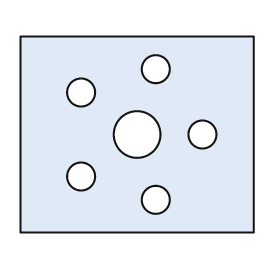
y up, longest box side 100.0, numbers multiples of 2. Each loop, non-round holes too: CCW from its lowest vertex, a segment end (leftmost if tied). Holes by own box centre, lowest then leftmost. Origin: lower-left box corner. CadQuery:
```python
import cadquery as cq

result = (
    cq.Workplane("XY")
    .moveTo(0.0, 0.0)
    .lineTo(100.0, 0.0)
    .lineTo(100.0, 84.0)
    .lineTo(0.0, 84.0)
    .close()
    .moveTo(58.0, 14.0)
    .circle(6.0)
    .moveTo(26.0, 24.0)
    .circle(6.0)
    .moveTo(50.0, 42.0)
    .circle(10.0)
    .moveTo(78.0, 42.0)
    .circle(6.0)
    .moveTo(26.0, 60.0)
    .circle(6.0)
    .moveTo(58.0, 70.0)
    .circle(6.0)
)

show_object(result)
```